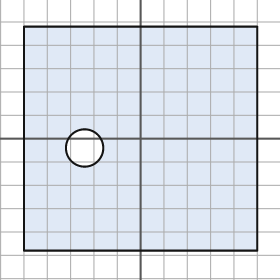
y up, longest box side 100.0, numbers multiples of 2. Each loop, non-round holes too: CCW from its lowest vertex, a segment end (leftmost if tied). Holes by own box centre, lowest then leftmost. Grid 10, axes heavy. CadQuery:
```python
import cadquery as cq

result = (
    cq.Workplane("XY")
    .moveTo(-50.0, -48.0)
    .lineTo(50.0, -48.0)
    .lineTo(50.0, 48.0)
    .lineTo(-50.0, 48.0)
    .close()
    .moveTo(-24.0, -4.0)
    .circle(8.0)
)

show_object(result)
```